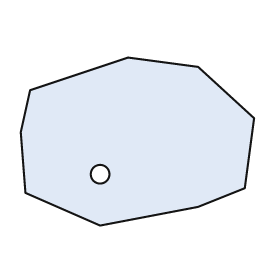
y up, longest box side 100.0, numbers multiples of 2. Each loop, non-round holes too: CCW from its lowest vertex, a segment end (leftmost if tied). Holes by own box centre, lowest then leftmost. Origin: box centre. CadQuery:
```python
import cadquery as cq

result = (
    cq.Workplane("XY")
    .moveTo(-16.0, -36.0)
    .lineTo(26.0, -28.0)
    .lineTo(46.0, -20.0)
    .lineTo(50.0, 10.0)
    .lineTo(26.0, 32.0)
    .lineTo(-4.0, 36.0)
    .lineTo(-46.0, 22.0)
    .lineTo(-50.0, 4.0)
    .lineTo(-48.0, -22.0)
    .close()
    .moveTo(-16.0, -14.0)
    .circle(4.0)
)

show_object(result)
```